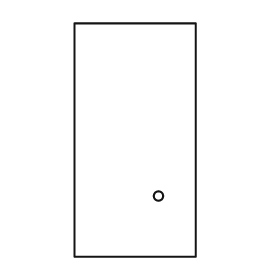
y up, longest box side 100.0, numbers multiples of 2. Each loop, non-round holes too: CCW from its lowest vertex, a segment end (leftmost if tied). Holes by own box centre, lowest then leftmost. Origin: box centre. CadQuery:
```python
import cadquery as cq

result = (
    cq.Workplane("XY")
    .moveTo(-26.0, -50.0)
    .lineTo(26.0, -50.0)
    .lineTo(26.0, 50.0)
    .lineTo(-26.0, 50.0)
    .close()
    .moveTo(10.0, -24.0)
    .circle(2.0)
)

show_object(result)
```